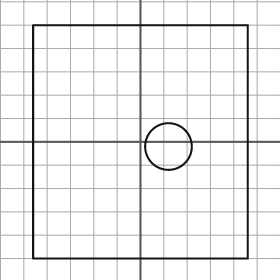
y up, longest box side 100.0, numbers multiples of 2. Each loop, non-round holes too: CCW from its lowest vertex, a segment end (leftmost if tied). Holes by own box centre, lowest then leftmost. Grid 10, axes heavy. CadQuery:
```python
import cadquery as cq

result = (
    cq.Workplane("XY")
    .moveTo(-46.0, -50.0)
    .lineTo(46.0, -50.0)
    .lineTo(46.0, 50.0)
    .lineTo(-46.0, 50.0)
    .close()
    .moveTo(12.0, -2.0)
    .circle(10.0)
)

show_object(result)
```